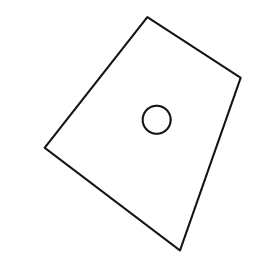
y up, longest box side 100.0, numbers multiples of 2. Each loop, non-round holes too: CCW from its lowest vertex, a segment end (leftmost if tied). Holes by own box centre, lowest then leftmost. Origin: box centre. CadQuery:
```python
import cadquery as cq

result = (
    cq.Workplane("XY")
    .moveTo(16.0, -50.0)
    .lineTo(42.0, 24.0)
    .lineTo(2.0, 50.0)
    .lineTo(-42.0, -6.0)
    .close()
    .moveTo(6.0, 6.0)
    .circle(6.0)
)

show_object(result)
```